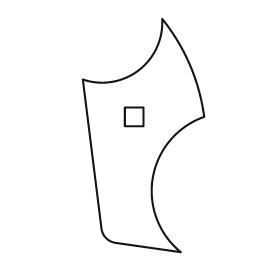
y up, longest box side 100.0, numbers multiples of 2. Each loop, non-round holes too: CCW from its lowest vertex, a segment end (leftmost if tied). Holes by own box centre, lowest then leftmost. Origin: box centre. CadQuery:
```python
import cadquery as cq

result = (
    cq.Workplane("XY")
    .moveTo(16.0, -50.0)
    .threePointArc((4.0, -18.0), (26.0, 8.0))
    .threePointArc((20.0, 30.0), (8.0, 50.0))
    .threePointArc((-2.0, 28.0), (-26.0, 24.0))
    .lineTo(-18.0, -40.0)
    .threePointArc((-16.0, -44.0), (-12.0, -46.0))
    .close()
    .moveTo(-8.0, 4.0)
    .lineTo(0.0, 4.0)
    .lineTo(0.0, 12.0)
    .lineTo(-8.0, 12.0)
    .close()
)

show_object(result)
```